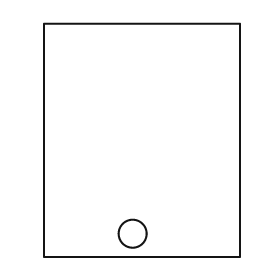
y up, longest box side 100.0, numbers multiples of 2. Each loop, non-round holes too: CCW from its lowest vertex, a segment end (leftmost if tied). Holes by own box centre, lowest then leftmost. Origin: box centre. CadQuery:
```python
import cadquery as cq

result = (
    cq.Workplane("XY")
    .moveTo(-42.0, -50.0)
    .lineTo(42.0, -50.0)
    .lineTo(42.0, 50.0)
    .lineTo(-42.0, 50.0)
    .close()
    .moveTo(-4.0, -40.0)
    .circle(6.0)
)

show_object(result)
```